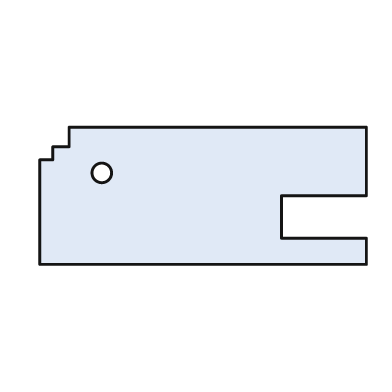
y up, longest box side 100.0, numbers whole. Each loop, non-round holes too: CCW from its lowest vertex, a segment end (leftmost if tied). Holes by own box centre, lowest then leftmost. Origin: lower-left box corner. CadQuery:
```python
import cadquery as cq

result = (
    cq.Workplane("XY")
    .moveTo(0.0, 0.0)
    .lineTo(100.0, 0.0)
    .lineTo(100.0, 8.0)
    .lineTo(74.0, 8.0)
    .lineTo(74.0, 21.0)
    .lineTo(100.0, 21.0)
    .lineTo(100.0, 42.0)
    .lineTo(9.0, 42.0)
    .lineTo(9.0, 36.0)
    .lineTo(4.0, 36.0)
    .lineTo(4.0, 32.0)
    .lineTo(0.0, 32.0)
    .close()
    .moveTo(19.0, 28.0)
    .circle(3.0)
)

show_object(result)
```